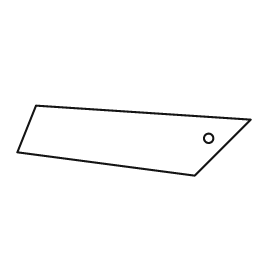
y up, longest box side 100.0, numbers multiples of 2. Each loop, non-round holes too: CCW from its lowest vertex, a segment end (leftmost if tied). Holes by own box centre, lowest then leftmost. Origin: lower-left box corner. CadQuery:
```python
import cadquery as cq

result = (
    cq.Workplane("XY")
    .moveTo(76.0, 0.0)
    .lineTo(100.0, 24.0)
    .lineTo(8.0, 30.0)
    .lineTo(0.0, 10.0)
    .close()
    .moveTo(82.0, 16.0)
    .circle(2.0)
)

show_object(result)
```